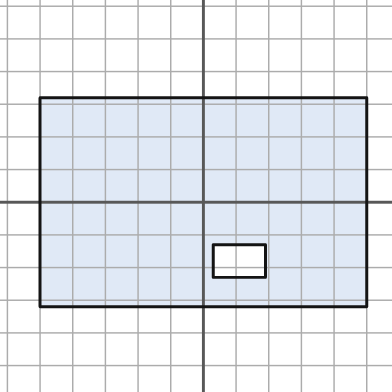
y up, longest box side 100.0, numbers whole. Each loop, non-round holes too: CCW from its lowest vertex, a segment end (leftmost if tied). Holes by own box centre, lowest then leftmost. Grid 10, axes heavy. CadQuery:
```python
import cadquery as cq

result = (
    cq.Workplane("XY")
    .moveTo(-50.0, -32.0)
    .lineTo(50.0, -32.0)
    .lineTo(50.0, 32.0)
    .lineTo(-50.0, 32.0)
    .close()
    .moveTo(3.0, -23.0)
    .lineTo(19.0, -23.0)
    .lineTo(19.0, -13.0)
    .lineTo(3.0, -13.0)
    .close()
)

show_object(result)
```